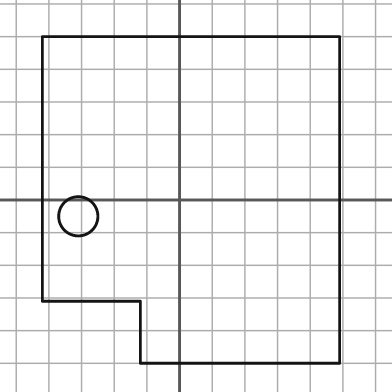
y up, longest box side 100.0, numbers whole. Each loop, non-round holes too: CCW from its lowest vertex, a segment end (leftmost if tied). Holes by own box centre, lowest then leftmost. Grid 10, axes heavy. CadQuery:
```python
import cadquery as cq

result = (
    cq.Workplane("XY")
    .moveTo(-12.0, -50.0)
    .lineTo(49.0, -50.0)
    .lineTo(49.0, 50.0)
    .lineTo(-42.0, 50.0)
    .lineTo(-42.0, -31.0)
    .lineTo(-12.0, -31.0)
    .close()
    .moveTo(-31.0, -5.0)
    .circle(6.0)
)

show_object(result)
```